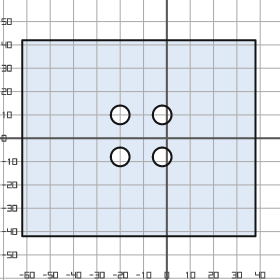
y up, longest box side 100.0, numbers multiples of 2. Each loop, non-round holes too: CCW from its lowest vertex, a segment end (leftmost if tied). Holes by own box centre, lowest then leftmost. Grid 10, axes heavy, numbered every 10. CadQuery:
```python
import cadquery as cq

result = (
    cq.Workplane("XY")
    .moveTo(-62.0, -42.0)
    .lineTo(38.0, -42.0)
    .lineTo(38.0, 42.0)
    .lineTo(-62.0, 42.0)
    .close()
    .moveTo(-20.0, -8.0)
    .circle(4.0)
    .moveTo(-2.0, -8.0)
    .circle(4.0)
    .moveTo(-20.0, 10.0)
    .circle(4.0)
    .moveTo(-2.0, 10.0)
    .circle(4.0)
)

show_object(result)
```